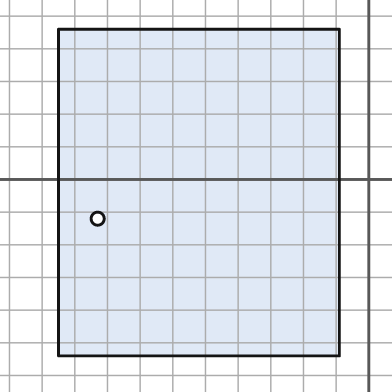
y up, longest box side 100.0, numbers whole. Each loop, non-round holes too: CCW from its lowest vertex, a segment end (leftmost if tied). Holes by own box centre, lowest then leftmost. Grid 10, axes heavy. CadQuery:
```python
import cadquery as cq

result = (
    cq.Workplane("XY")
    .moveTo(-95.0, -54.0)
    .lineTo(-9.0, -54.0)
    .lineTo(-9.0, 46.0)
    .lineTo(-95.0, 46.0)
    .close()
    .moveTo(-83.0, -12.0)
    .circle(2.0)
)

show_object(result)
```